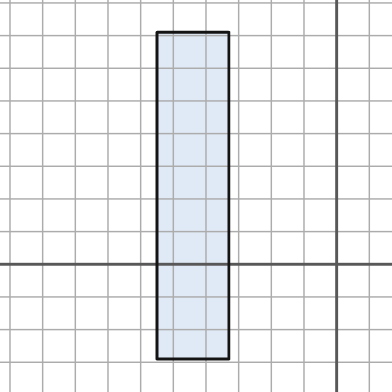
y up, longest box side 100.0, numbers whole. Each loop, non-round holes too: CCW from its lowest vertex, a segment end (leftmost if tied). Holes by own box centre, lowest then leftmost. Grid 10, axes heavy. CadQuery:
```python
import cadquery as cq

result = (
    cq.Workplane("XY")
    .moveTo(-55.0, -29.0)
    .lineTo(-33.0, -29.0)
    .lineTo(-33.0, 71.0)
    .lineTo(-55.0, 71.0)
    .close()
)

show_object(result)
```